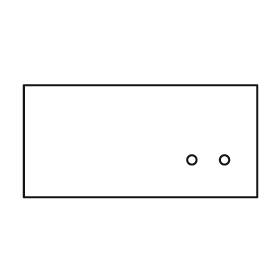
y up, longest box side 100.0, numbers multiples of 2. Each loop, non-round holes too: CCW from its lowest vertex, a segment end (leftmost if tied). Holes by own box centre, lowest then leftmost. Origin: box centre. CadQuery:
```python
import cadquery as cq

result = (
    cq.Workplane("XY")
    .moveTo(-50.0, -24.0)
    .lineTo(50.0, -24.0)
    .lineTo(50.0, 24.0)
    .lineTo(-50.0, 24.0)
    .close()
    .moveTo(22.0, -8.0)
    .circle(2.0)
    .moveTo(36.0, -8.0)
    .circle(2.0)
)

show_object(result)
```